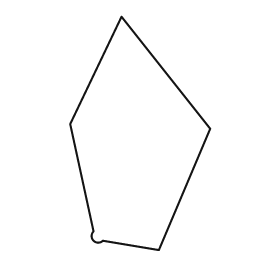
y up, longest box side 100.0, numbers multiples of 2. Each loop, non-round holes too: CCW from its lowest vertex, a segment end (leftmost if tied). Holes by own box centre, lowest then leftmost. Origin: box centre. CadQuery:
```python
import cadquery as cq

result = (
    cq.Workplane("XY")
    .moveTo(8.0, -50.0)
    .lineTo(30.0, 2.0)
    .lineTo(-8.0, 50.0)
    .lineTo(-30.0, 4.0)
    .lineTo(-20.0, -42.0)
    .threePointArc((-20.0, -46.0), (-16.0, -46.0))
    .close()
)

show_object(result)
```